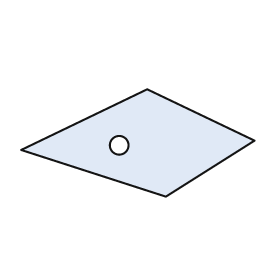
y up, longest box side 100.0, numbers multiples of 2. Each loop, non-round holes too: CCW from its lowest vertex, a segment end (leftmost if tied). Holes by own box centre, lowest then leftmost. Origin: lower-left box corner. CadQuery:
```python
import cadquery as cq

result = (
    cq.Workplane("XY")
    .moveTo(62.0, 0.0)
    .lineTo(100.0, 24.0)
    .lineTo(54.0, 46.0)
    .lineTo(0.0, 20.0)
    .close()
    .moveTo(42.0, 22.0)
    .circle(4.0)
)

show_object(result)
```